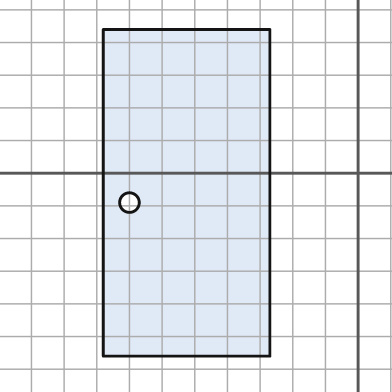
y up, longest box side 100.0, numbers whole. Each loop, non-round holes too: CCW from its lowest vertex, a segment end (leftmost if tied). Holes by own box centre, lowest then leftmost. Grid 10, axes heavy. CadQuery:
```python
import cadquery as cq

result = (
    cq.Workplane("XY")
    .moveTo(-78.0, -56.0)
    .lineTo(-27.0, -56.0)
    .lineTo(-27.0, 44.0)
    .lineTo(-78.0, 44.0)
    .close()
    .moveTo(-70.0, -9.0)
    .circle(3.0)
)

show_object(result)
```